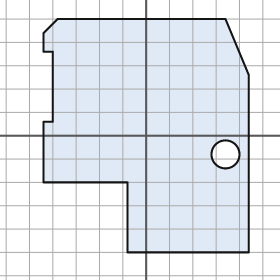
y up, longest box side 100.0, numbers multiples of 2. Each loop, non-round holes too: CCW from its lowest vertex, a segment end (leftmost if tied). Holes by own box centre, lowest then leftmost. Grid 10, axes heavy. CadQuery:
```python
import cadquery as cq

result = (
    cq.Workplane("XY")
    .moveTo(-8.0, -50.0)
    .lineTo(44.0, -50.0)
    .lineTo(44.0, 26.0)
    .lineTo(34.0, 50.0)
    .lineTo(-38.0, 50.0)
    .lineTo(-44.0, 44.0)
    .lineTo(-44.0, 36.0)
    .lineTo(-40.0, 36.0)
    .lineTo(-40.0, 6.0)
    .lineTo(-44.0, 6.0)
    .lineTo(-44.0, -20.0)
    .lineTo(-8.0, -20.0)
    .close()
    .moveTo(34.0, -8.0)
    .circle(6.0)
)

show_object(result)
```